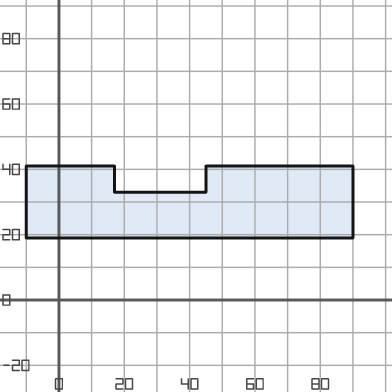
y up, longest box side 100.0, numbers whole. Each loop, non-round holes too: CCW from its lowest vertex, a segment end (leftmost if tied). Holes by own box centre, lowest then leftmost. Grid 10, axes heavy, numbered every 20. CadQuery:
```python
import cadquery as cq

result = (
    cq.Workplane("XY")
    .moveTo(-10.0, 19.0)
    .lineTo(90.0, 19.0)
    .lineTo(90.0, 41.0)
    .lineTo(45.0, 41.0)
    .lineTo(45.0, 33.0)
    .lineTo(17.0, 33.0)
    .lineTo(17.0, 41.0)
    .lineTo(-10.0, 41.0)
    .close()
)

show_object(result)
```